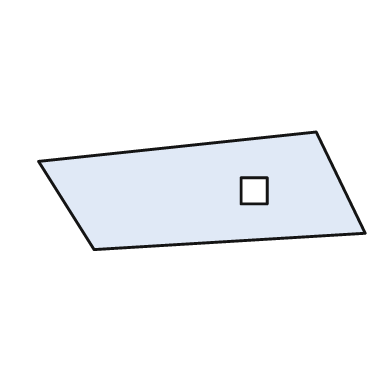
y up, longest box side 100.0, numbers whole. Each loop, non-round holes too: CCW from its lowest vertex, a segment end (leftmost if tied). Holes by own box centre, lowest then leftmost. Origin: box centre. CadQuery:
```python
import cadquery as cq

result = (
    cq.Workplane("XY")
    .moveTo(-33.0, -18.0)
    .lineTo(50.0, -13.0)
    .lineTo(35.0, 18.0)
    .lineTo(-50.0, 9.0)
    .close()
    .moveTo(12.0, -4.0)
    .lineTo(20.0, -4.0)
    .lineTo(20.0, 4.0)
    .lineTo(12.0, 4.0)
    .close()
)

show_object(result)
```